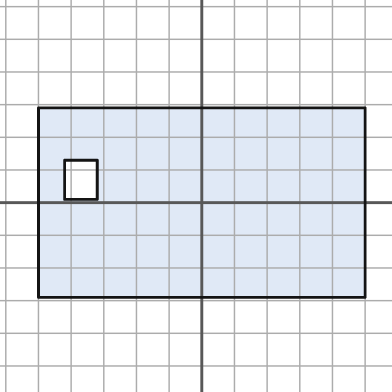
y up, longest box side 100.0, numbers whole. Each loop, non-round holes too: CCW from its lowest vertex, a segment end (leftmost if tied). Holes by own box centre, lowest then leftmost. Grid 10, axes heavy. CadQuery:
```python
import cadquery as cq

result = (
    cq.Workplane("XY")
    .moveTo(-50.0, -29.0)
    .lineTo(50.0, -29.0)
    .lineTo(50.0, 29.0)
    .lineTo(-50.0, 29.0)
    .close()
    .moveTo(-42.0, 1.0)
    .lineTo(-32.0, 1.0)
    .lineTo(-32.0, 13.0)
    .lineTo(-42.0, 13.0)
    .close()
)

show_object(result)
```